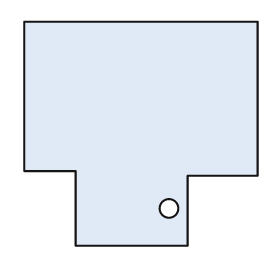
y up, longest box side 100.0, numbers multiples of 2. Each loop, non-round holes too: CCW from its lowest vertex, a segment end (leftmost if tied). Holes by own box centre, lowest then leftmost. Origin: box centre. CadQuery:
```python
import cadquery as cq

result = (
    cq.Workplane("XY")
    .moveTo(-28.0, -48.0)
    .lineTo(20.0, -48.0)
    .lineTo(20.0, -18.0)
    .lineTo(50.0, -18.0)
    .lineTo(50.0, 48.0)
    .lineTo(-50.0, 48.0)
    .lineTo(-50.0, -16.0)
    .lineTo(-28.0, -16.0)
    .close()
    .moveTo(12.0, -32.0)
    .circle(4.0)
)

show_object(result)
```